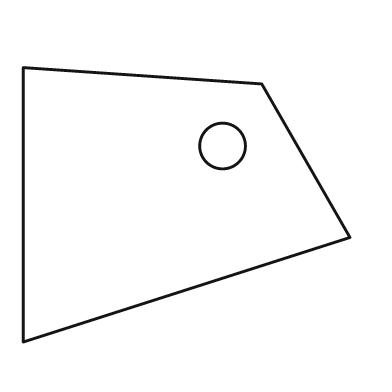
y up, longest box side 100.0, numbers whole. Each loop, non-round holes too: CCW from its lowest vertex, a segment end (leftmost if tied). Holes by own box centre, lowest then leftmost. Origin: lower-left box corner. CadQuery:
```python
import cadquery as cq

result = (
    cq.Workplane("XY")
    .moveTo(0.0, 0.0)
    .lineTo(100.0, 32.0)
    .lineTo(73.0, 79.0)
    .lineTo(0.0, 84.0)
    .close()
    .moveTo(61.0, 60.0)
    .circle(7.0)
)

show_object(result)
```